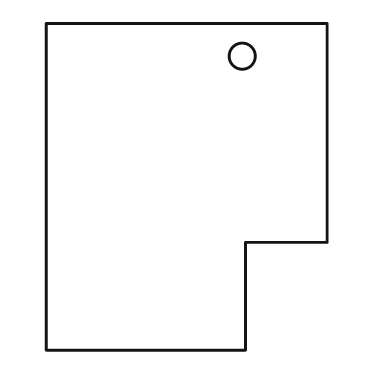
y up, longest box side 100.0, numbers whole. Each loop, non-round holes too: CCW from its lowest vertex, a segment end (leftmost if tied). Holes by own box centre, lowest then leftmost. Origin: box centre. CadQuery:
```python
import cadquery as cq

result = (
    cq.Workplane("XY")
    .moveTo(-43.0, -50.0)
    .lineTo(18.0, -50.0)
    .lineTo(18.0, -17.0)
    .lineTo(43.0, -17.0)
    .lineTo(43.0, 50.0)
    .lineTo(-43.0, 50.0)
    .close()
    .moveTo(17.0, 40.0)
    .circle(4.0)
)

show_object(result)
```